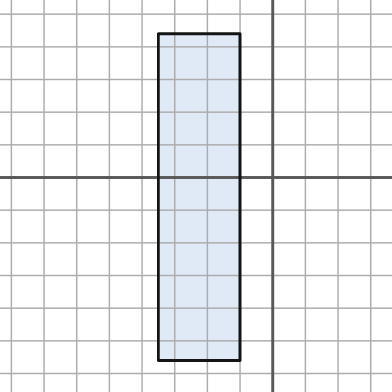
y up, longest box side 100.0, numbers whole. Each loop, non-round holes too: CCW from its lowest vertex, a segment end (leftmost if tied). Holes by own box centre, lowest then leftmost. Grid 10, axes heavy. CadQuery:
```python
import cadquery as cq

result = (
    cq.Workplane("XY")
    .moveTo(-35.0, -56.0)
    .lineTo(-10.0, -56.0)
    .lineTo(-10.0, 44.0)
    .lineTo(-35.0, 44.0)
    .close()
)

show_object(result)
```